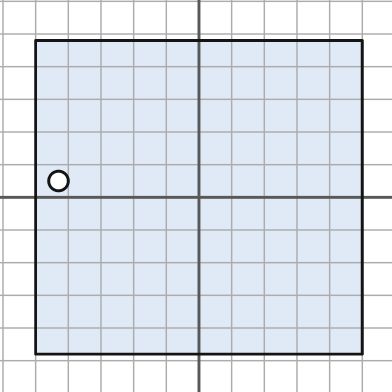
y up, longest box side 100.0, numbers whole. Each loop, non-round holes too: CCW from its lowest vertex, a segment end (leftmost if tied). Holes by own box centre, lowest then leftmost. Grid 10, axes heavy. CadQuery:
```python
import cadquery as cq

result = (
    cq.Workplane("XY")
    .moveTo(-50.0, -48.0)
    .lineTo(50.0, -48.0)
    .lineTo(50.0, 48.0)
    .lineTo(-50.0, 48.0)
    .close()
    .moveTo(-43.0, 5.0)
    .circle(3.0)
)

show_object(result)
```